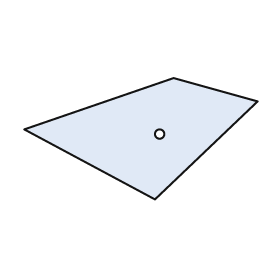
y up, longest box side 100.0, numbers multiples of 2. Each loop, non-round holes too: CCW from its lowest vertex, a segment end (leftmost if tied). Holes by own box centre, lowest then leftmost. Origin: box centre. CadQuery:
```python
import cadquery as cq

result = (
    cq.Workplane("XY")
    .moveTo(6.0, -26.0)
    .lineTo(50.0, 16.0)
    .lineTo(14.0, 26.0)
    .lineTo(-50.0, 4.0)
    .close()
    .moveTo(8.0, 2.0)
    .circle(2.0)
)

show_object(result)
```